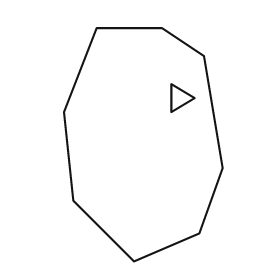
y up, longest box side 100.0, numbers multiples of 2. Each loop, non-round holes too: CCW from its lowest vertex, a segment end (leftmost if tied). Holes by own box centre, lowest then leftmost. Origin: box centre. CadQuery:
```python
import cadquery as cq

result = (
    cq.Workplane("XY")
    .moveTo(-4.0, -50.0)
    .lineTo(24.0, -38.0)
    .lineTo(34.0, -10.0)
    .lineTo(26.0, 38.0)
    .lineTo(8.0, 50.0)
    .lineTo(-20.0, 50.0)
    .lineTo(-34.0, 14.0)
    .lineTo(-30.0, -24.0)
    .close()
    .moveTo(12.0, 14.0)
    .lineTo(22.0, 20.0)
    .lineTo(12.0, 26.0)
    .close()
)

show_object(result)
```